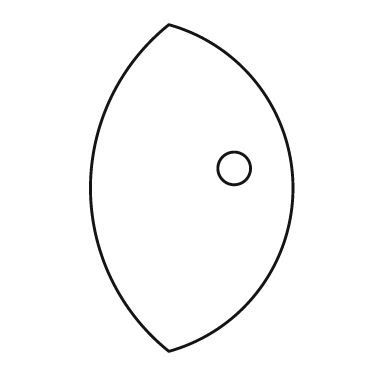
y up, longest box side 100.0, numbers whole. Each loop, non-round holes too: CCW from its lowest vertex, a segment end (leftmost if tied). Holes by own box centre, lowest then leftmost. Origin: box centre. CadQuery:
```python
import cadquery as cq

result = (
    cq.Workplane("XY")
    .moveTo(-7.0, -50.0)
    .threePointArc((31.0, 0.0), (-7.0, 50.0))
    .threePointArc((-31.0, 0.0), (-7.0, -50.0))
    .close()
    .moveTo(13.0, 6.0)
    .circle(5.0)
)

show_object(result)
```